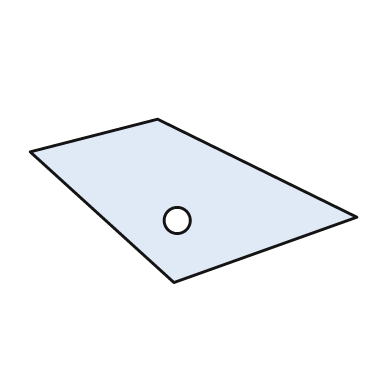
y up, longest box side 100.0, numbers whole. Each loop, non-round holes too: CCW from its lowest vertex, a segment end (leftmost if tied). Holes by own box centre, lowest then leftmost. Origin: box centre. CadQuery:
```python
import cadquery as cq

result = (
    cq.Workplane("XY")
    .moveTo(-6.0, -25.0)
    .lineTo(50.0, -5.0)
    .lineTo(-11.0, 25.0)
    .lineTo(-50.0, 15.0)
    .close()
    .moveTo(-5.0, -6.0)
    .circle(4.0)
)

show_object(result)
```